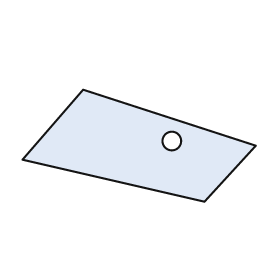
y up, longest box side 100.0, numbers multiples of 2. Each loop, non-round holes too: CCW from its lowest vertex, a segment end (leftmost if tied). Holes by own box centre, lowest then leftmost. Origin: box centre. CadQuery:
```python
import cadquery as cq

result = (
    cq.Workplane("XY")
    .moveTo(28.0, -24.0)
    .lineTo(50.0, 0.0)
    .lineTo(-24.0, 24.0)
    .lineTo(-50.0, -6.0)
    .close()
    .moveTo(14.0, 2.0)
    .circle(4.0)
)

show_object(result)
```